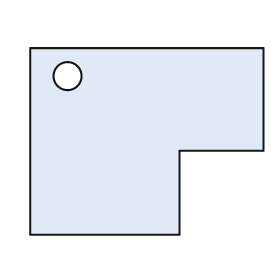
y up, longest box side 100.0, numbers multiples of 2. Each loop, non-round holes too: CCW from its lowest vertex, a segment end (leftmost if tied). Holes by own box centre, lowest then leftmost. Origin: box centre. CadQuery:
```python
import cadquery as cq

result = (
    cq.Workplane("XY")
    .moveTo(-50.0, -40.0)
    .lineTo(14.0, -40.0)
    .lineTo(14.0, -4.0)
    .lineTo(50.0, -4.0)
    .lineTo(50.0, 40.0)
    .lineTo(-50.0, 40.0)
    .close()
    .moveTo(-34.0, 28.0)
    .circle(6.0)
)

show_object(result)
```